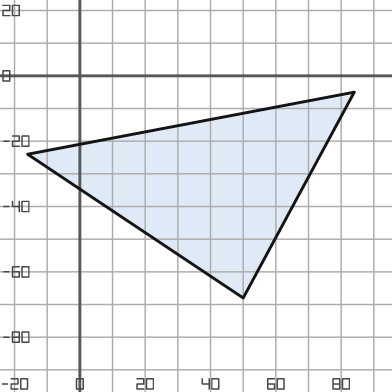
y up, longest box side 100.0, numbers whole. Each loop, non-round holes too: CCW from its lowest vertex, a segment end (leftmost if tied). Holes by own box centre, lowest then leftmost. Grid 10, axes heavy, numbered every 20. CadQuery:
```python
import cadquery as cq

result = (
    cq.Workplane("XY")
    .moveTo(50.0, -68.0)
    .lineTo(84.0, -5.0)
    .lineTo(-16.0, -24.0)
    .close()
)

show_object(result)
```